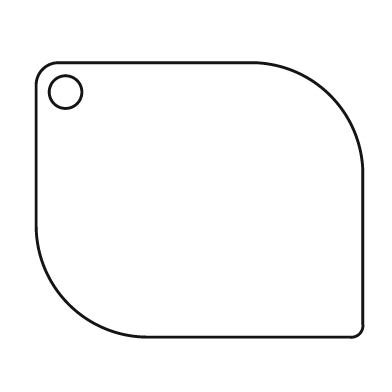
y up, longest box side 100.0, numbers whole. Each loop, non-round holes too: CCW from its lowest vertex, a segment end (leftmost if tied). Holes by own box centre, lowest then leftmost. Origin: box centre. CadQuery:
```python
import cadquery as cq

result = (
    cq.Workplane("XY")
    .moveTo(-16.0, -42.0)
    .lineTo(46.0, -42.0)
    .threePointArc((49.0, -41.0), (50.0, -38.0))
    .lineTo(50.0, 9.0)
    .threePointArc((40.0, 32.0), (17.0, 42.0))
    .lineTo(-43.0, 42.0)
    .threePointArc((-48.0, 40.0), (-50.0, 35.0))
    .lineTo(-50.0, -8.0)
    .threePointArc((-40.0, -32.0), (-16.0, -42.0))
    .close()
    .moveTo(-41.0, 33.0)
    .circle(5.0)
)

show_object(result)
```